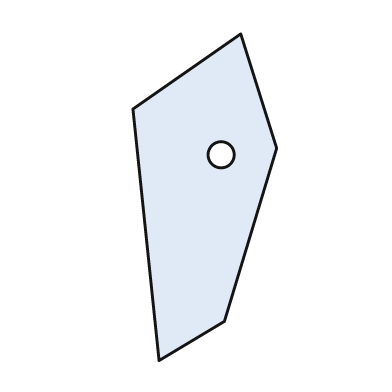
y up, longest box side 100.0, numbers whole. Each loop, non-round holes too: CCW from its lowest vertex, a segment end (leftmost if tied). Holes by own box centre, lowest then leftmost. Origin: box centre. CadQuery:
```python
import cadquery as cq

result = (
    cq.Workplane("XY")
    .moveTo(-14.0, -50.0)
    .lineTo(6.0, -38.0)
    .lineTo(22.0, 15.0)
    .lineTo(11.0, 50.0)
    .lineTo(-22.0, 27.0)
    .close()
    .moveTo(5.0, 13.0)
    .circle(4.0)
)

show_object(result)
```